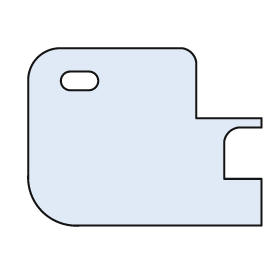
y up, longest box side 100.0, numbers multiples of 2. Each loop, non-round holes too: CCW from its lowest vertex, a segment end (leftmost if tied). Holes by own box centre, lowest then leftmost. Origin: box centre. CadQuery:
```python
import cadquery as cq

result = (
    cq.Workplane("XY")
    .moveTo(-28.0, -38.0)
    .lineTo(50.0, -38.0)
    .lineTo(50.0, -18.0)
    .lineTo(34.0, -18.0)
    .lineTo(34.0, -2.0)
    .threePointArc((36.0, 2.0), (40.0, 4.0))
    .lineTo(50.0, 4.0)
    .lineTo(50.0, 8.0)
    .lineTo(22.0, 8.0)
    .lineTo(22.0, 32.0)
    .threePointArc((20.0, 36.0), (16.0, 38.0))
    .lineTo(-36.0, 38.0)
    .threePointArc((-46.0, 34.0), (-50.0, 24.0))
    .lineTo(-50.0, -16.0)
    .threePointArc((-44.0, -32.0), (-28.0, -38.0))
    .close()
    .moveTo(-32.0, 20.0)
    .lineTo(-24.0, 20.0)
    .threePointArc((-20.0, 24.0), (-24.0, 28.0))
    .lineTo(-32.0, 28.0)
    .threePointArc((-36.0, 24.0), (-32.0, 20.0))
    .close()
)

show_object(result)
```